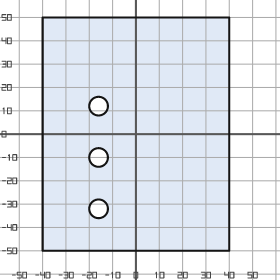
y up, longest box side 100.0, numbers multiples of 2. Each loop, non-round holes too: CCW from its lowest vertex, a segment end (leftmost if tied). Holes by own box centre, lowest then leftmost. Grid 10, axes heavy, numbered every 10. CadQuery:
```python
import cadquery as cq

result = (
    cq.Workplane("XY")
    .moveTo(-40.0, -50.0)
    .lineTo(40.0, -50.0)
    .lineTo(40.0, 50.0)
    .lineTo(-40.0, 50.0)
    .close()
    .moveTo(-16.0, -32.0)
    .circle(4.0)
    .moveTo(-16.0, -10.0)
    .circle(4.0)
    .moveTo(-16.0, 12.0)
    .circle(4.0)
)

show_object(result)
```